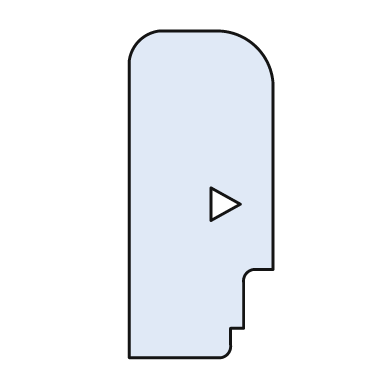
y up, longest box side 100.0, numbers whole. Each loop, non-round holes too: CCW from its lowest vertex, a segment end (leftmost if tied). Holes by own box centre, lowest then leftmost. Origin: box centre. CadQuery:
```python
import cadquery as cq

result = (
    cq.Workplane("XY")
    .moveTo(-22.0, -50.0)
    .lineTo(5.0, -50.0)
    .threePointArc((8.0, -49.0), (9.0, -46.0))
    .lineTo(9.0, -41.0)
    .lineTo(13.0, -41.0)
    .lineTo(13.0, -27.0)
    .threePointArc((14.0, -24.0), (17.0, -23.0))
    .lineTo(22.0, -23.0)
    .lineTo(22.0, 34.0)
    .threePointArc((17.0, 45.0), (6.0, 50.0))
    .lineTo(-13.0, 50.0)
    .threePointArc((-19.0, 47.0), (-22.0, 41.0))
    .close()
    .moveTo(3.0, -8.0)
    .lineTo(12.0, -3.0)
    .lineTo(3.0, 2.0)
    .close()
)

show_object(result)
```